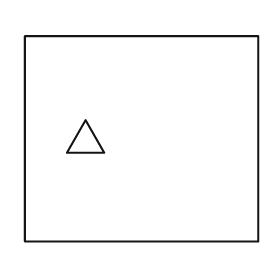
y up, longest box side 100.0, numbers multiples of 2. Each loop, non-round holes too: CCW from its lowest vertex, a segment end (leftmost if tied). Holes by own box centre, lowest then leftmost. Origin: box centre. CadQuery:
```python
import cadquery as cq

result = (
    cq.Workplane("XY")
    .moveTo(-50.0, -44.0)
    .lineTo(50.0, -44.0)
    .lineTo(50.0, 44.0)
    .lineTo(-50.0, 44.0)
    .close()
    .moveTo(-32.0, -6.0)
    .lineTo(-16.0, -6.0)
    .lineTo(-24.0, 8.0)
    .close()
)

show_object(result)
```